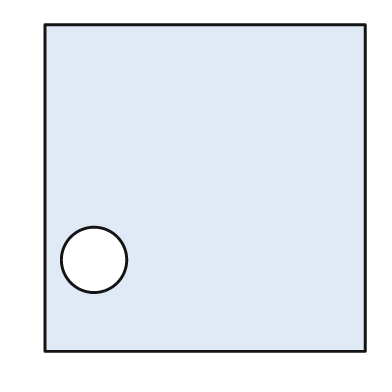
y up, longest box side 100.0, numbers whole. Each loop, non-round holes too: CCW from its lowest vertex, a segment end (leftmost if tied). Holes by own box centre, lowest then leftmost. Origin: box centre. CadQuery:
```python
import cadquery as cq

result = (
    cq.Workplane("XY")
    .moveTo(-49.0, -50.0)
    .lineTo(49.0, -50.0)
    .lineTo(49.0, 50.0)
    .lineTo(-49.0, 50.0)
    .close()
    .moveTo(-34.0, -22.0)
    .circle(10.0)
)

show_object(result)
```